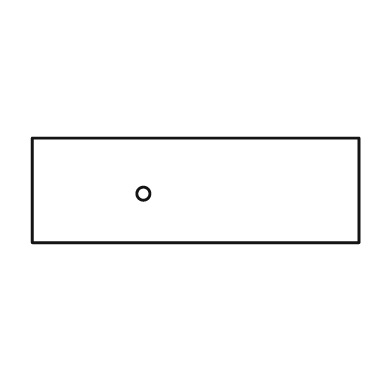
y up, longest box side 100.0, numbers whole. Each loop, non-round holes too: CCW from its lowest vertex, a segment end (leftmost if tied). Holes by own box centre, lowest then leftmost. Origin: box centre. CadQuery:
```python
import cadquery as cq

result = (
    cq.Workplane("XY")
    .moveTo(-50.0, -16.0)
    .lineTo(50.0, -16.0)
    .lineTo(50.0, 16.0)
    .lineTo(-50.0, 16.0)
    .close()
    .moveTo(-16.0, -1.0)
    .circle(2.0)
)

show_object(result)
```